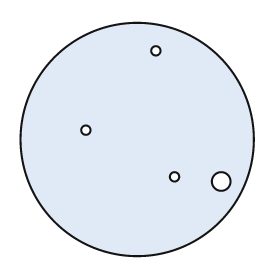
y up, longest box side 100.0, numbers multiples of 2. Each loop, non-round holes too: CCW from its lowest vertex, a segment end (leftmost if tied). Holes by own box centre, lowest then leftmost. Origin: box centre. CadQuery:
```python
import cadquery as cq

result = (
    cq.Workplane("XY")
    .moveTo(0.0, 0.0)
    .circle(50.0)
    .moveTo(36.0, -18.0)
    .circle(4.0)
    .moveTo(16.0, -16.0)
    .circle(2.0)
    .moveTo(-22.0, 4.0)
    .circle(2.0)
    .moveTo(8.0, 38.0)
    .circle(2.0)
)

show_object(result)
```